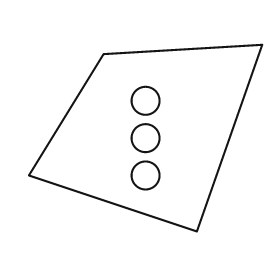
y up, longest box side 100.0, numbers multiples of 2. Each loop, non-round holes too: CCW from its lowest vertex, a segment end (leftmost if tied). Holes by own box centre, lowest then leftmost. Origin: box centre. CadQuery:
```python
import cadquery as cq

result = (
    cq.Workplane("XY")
    .moveTo(22.0, -40.0)
    .lineTo(50.0, 40.0)
    .lineTo(-18.0, 36.0)
    .lineTo(-50.0, -16.0)
    .close()
    .moveTo(0.0, -16.0)
    .circle(6.0)
    .moveTo(0.0, 0.0)
    .circle(6.0)
    .moveTo(0.0, 16.0)
    .circle(6.0)
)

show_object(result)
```